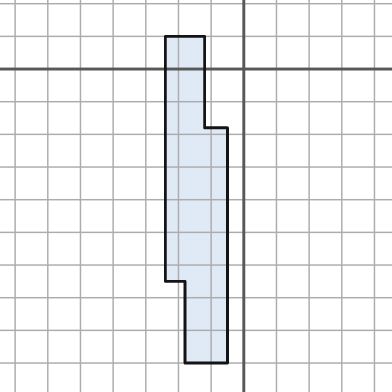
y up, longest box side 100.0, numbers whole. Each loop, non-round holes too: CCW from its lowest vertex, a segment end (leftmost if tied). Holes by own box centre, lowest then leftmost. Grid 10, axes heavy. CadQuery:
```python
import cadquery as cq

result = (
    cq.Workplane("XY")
    .moveTo(-18.0, -90.0)
    .lineTo(-5.0, -90.0)
    .lineTo(-5.0, -18.0)
    .lineTo(-12.0, -18.0)
    .lineTo(-12.0, 10.0)
    .lineTo(-24.0, 10.0)
    .lineTo(-24.0, -65.0)
    .lineTo(-18.0, -65.0)
    .close()
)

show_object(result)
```